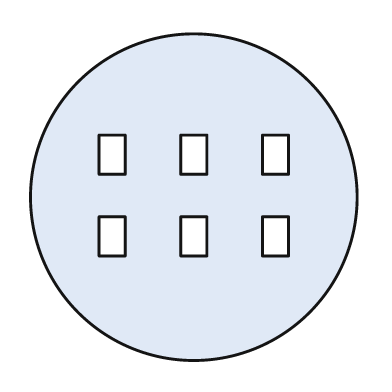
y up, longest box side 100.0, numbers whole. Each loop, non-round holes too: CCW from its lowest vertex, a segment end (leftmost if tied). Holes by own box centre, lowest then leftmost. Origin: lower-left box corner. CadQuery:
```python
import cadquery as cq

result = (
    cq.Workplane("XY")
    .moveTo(50.0, 50.0)
    .circle(50.0)
    .moveTo(21.0, 32.0)
    .lineTo(29.0, 32.0)
    .lineTo(29.0, 44.0)
    .lineTo(21.0, 44.0)
    .close()
    .moveTo(46.0, 32.0)
    .lineTo(54.0, 32.0)
    .lineTo(54.0, 44.0)
    .lineTo(46.0, 44.0)
    .close()
    .moveTo(71.0, 32.0)
    .lineTo(79.0, 32.0)
    .lineTo(79.0, 44.0)
    .lineTo(71.0, 44.0)
    .close()
    .moveTo(21.0, 57.0)
    .lineTo(29.0, 57.0)
    .lineTo(29.0, 69.0)
    .lineTo(21.0, 69.0)
    .close()
    .moveTo(46.0, 57.0)
    .lineTo(54.0, 57.0)
    .lineTo(54.0, 69.0)
    .lineTo(46.0, 69.0)
    .close()
    .moveTo(71.0, 57.0)
    .lineTo(79.0, 57.0)
    .lineTo(79.0, 69.0)
    .lineTo(71.0, 69.0)
    .close()
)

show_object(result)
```